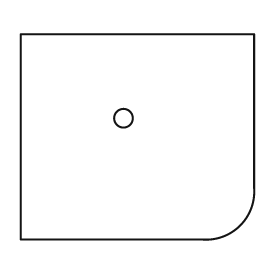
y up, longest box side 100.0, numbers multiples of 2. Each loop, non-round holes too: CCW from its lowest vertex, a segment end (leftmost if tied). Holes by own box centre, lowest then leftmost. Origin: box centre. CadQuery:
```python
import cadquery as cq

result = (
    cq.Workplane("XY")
    .moveTo(-50.0, -44.0)
    .lineTo(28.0, -44.0)
    .threePointArc((44.0, -38.0), (50.0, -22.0))
    .lineTo(50.0, 44.0)
    .lineTo(-50.0, 44.0)
    .close()
    .moveTo(-6.0, 8.0)
    .circle(4.0)
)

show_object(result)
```